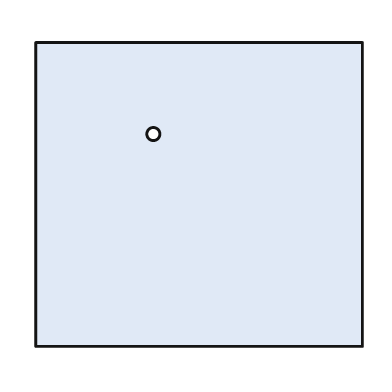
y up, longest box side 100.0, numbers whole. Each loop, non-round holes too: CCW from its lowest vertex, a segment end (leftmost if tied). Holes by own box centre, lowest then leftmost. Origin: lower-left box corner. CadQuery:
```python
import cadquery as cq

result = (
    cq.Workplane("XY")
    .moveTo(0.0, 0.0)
    .lineTo(100.0, 0.0)
    .lineTo(100.0, 93.0)
    .lineTo(0.0, 93.0)
    .close()
    .moveTo(36.0, 65.0)
    .circle(2.0)
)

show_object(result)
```